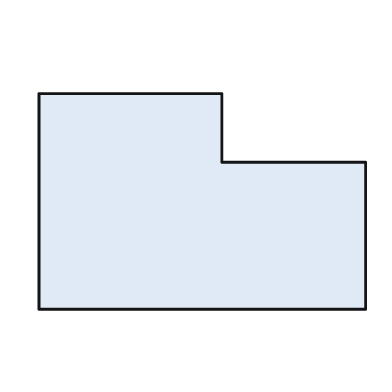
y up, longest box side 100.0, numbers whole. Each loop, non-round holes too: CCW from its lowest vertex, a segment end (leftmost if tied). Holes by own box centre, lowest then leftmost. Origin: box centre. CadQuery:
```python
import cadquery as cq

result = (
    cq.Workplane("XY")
    .moveTo(-50.0, -33.0)
    .lineTo(50.0, -33.0)
    .lineTo(50.0, 12.0)
    .lineTo(6.0, 12.0)
    .lineTo(6.0, 33.0)
    .lineTo(-50.0, 33.0)
    .close()
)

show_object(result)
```